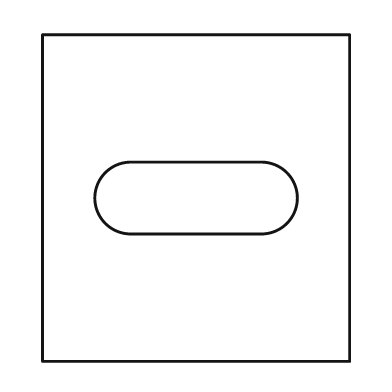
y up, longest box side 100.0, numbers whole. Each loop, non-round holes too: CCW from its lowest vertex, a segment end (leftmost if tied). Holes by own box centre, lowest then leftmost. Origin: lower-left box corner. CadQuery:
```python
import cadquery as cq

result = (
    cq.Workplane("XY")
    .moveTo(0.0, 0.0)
    .lineTo(94.0, 0.0)
    .lineTo(94.0, 100.0)
    .lineTo(0.0, 100.0)
    .close()
    .moveTo(27.0, 39.0)
    .lineTo(67.0, 39.0)
    .threePointArc((78.0, 50.0), (67.0, 61.0))
    .lineTo(27.0, 61.0)
    .threePointArc((16.0, 50.0), (27.0, 39.0))
    .close()
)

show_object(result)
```